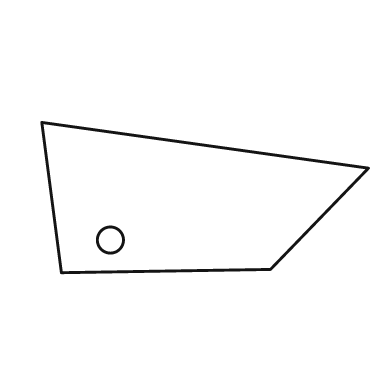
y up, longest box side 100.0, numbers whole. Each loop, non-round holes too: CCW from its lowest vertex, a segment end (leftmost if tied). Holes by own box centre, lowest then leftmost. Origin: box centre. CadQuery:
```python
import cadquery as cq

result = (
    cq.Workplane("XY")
    .moveTo(-44.0, -23.0)
    .lineTo(20.0, -22.0)
    .lineTo(50.0, 9.0)
    .lineTo(-50.0, 23.0)
    .close()
    .moveTo(-29.0, -13.0)
    .circle(4.0)
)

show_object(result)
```